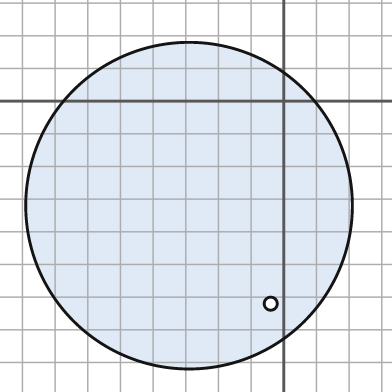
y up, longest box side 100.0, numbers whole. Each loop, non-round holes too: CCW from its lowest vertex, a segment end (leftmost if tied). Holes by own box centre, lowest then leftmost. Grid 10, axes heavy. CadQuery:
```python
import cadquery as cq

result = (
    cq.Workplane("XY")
    .moveTo(-29.0, -32.0)
    .circle(50.0)
    .moveTo(-4.0, -62.0)
    .circle(2.0)
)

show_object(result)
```